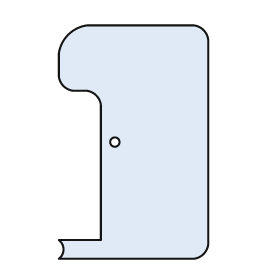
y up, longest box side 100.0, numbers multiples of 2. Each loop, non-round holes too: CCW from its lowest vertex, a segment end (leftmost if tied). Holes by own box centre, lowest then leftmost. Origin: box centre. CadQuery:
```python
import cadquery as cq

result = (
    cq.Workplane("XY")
    .moveTo(-32.0, -50.0)
    .lineTo(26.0, -50.0)
    .threePointArc((30.0, -48.0), (32.0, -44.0))
    .lineTo(32.0, 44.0)
    .threePointArc((30.0, 48.0), (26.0, 50.0))
    .lineTo(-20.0, 50.0)
    .threePointArc((-28.0, 46.0), (-32.0, 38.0))
    .lineTo(-32.0, 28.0)
    .threePointArc((-30.0, 24.0), (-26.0, 22.0))
    .lineTo(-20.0, 22.0)
    .threePointArc((-16.0, 20.0), (-14.0, 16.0))
    .lineTo(-14.0, -42.0)
    .lineTo(-32.0, -42.0)
    .threePointArc((-30.0, -46.0), (-32.0, -50.0))
    .close()
    .moveTo(-8.0, 0.0)
    .circle(2.0)
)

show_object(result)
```